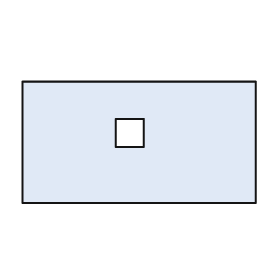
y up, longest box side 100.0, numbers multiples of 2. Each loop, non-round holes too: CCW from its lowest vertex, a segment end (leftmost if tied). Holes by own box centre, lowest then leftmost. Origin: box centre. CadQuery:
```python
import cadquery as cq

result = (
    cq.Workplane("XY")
    .moveTo(-50.0, -26.0)
    .lineTo(50.0, -26.0)
    .lineTo(50.0, 26.0)
    .lineTo(-50.0, 26.0)
    .close()
    .moveTo(-10.0, -2.0)
    .lineTo(2.0, -2.0)
    .lineTo(2.0, 10.0)
    .lineTo(-10.0, 10.0)
    .close()
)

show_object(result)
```